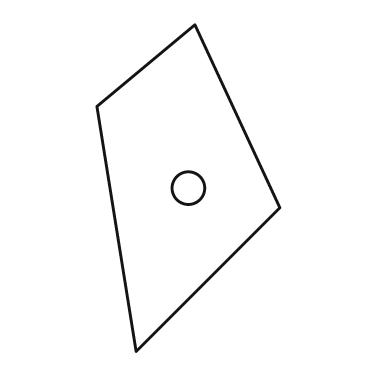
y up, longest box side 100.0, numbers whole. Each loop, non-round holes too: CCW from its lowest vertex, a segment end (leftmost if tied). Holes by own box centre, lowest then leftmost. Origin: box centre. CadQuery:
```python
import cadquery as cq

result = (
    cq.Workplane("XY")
    .moveTo(-16.0, -50.0)
    .lineTo(28.0, -6.0)
    .lineTo(2.0, 50.0)
    .lineTo(-28.0, 25.0)
    .close()
    .moveTo(0.0, 0.0)
    .circle(5.0)
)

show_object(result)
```